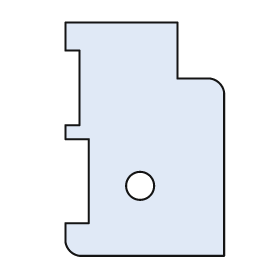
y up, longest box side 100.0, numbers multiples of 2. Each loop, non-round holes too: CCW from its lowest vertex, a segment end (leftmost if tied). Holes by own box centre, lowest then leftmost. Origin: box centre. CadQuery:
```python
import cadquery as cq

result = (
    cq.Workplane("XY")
    .moveTo(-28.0, -50.0)
    .lineTo(34.0, -50.0)
    .lineTo(34.0, 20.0)
    .threePointArc((32.0, 24.0), (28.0, 26.0))
    .lineTo(14.0, 26.0)
    .lineTo(14.0, 50.0)
    .lineTo(-34.0, 50.0)
    .lineTo(-34.0, 38.0)
    .lineTo(-28.0, 38.0)
    .lineTo(-28.0, 6.0)
    .lineTo(-34.0, 6.0)
    .lineTo(-34.0, 0.0)
    .lineTo(-24.0, 0.0)
    .lineTo(-24.0, -36.0)
    .lineTo(-34.0, -36.0)
    .lineTo(-34.0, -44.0)
    .threePointArc((-32.0, -48.0), (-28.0, -50.0))
    .close()
    .moveTo(-2.0, -20.0)
    .circle(6.0)
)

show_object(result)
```